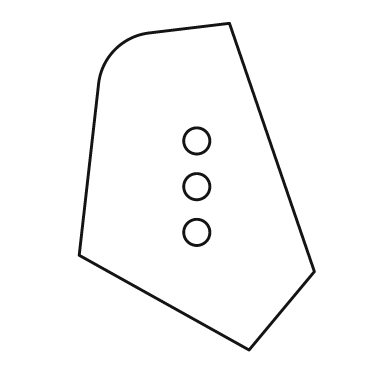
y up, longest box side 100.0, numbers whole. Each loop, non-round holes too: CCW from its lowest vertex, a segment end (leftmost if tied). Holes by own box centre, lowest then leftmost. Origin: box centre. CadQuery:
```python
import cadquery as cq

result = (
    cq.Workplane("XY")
    .moveTo(16.0, -50.0)
    .lineTo(36.0, -26.0)
    .lineTo(10.0, 50.0)
    .lineTo(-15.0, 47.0)
    .threePointArc((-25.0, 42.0), (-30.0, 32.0))
    .lineTo(-36.0, -21.0)
    .close()
    .moveTo(0.0, -14.0)
    .circle(4.0)
    .moveTo(0.0, 0.0)
    .circle(4.0)
    .moveTo(0.0, 14.0)
    .circle(4.0)
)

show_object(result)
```